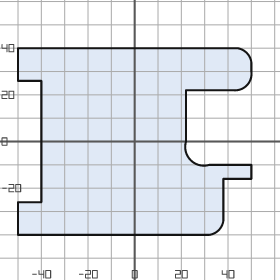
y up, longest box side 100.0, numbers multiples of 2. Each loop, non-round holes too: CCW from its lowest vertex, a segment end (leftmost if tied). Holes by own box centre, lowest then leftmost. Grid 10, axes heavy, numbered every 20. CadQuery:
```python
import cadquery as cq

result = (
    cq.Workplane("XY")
    .moveTo(-50.0, -40.0)
    .lineTo(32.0, -40.0)
    .threePointArc((36.0, -38.0), (38.0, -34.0))
    .lineTo(38.0, -16.0)
    .lineTo(50.0, -16.0)
    .lineTo(50.0, -10.0)
    .lineTo(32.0, -10.0)
    .threePointArc((24.0, -8.0), (22.0, 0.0))
    .lineTo(22.0, 22.0)
    .lineTo(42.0, 22.0)
    .threePointArc((48.0, 24.0), (50.0, 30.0))
    .lineTo(50.0, 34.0)
    .threePointArc((48.0, 38.0), (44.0, 40.0))
    .lineTo(-50.0, 40.0)
    .lineTo(-50.0, 26.0)
    .lineTo(-40.0, 26.0)
    .lineTo(-40.0, -26.0)
    .lineTo(-50.0, -26.0)
    .close()
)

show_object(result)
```